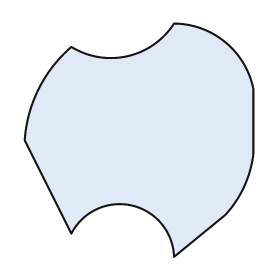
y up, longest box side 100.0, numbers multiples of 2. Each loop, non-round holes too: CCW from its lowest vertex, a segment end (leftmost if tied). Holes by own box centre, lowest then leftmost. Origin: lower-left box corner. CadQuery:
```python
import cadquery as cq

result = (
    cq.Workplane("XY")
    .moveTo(64.0, 0.0)
    .lineTo(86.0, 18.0)
    .threePointArc((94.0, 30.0), (98.0, 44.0))
    .lineTo(98.0, 72.0)
    .threePointArc((86.0, 92.0), (64.0, 100.0))
    .threePointArc((44.0, 86.0), (20.0, 90.0))
    .threePointArc((6.0, 72.0), (0.0, 50.0))
    .lineTo(20.0, 10.0)
    .threePointArc((46.0, 22.0), (64.0, 0.0))
    .close()
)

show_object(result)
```